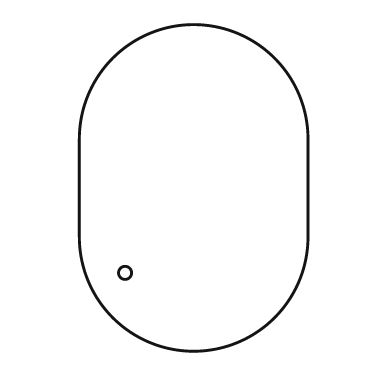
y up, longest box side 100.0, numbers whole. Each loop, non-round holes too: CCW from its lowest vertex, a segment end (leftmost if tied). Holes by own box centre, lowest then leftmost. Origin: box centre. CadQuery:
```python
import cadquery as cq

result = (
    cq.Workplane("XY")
    .moveTo(-35.0, -15.0)
    .threePointArc((0.0, -50.0), (35.0, -15.0))
    .lineTo(35.0, 15.0)
    .threePointArc((0.0, 50.0), (-35.0, 15.0))
    .close()
    .moveTo(-21.0, -26.0)
    .circle(2.0)
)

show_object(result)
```